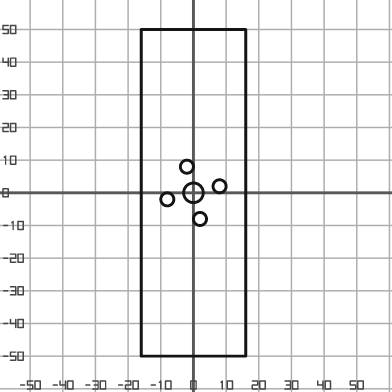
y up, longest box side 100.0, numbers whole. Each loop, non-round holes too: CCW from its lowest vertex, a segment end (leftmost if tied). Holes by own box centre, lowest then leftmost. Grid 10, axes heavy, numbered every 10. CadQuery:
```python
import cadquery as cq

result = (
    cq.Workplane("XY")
    .moveTo(-16.0, -50.0)
    .lineTo(16.0, -50.0)
    .lineTo(16.0, 50.0)
    .lineTo(-16.0, 50.0)
    .close()
    .moveTo(2.0, -8.0)
    .circle(2.0)
    .moveTo(-8.0, -2.0)
    .circle(2.0)
    .moveTo(0.0, 0.0)
    .circle(3.0)
    .moveTo(8.0, 2.0)
    .circle(2.0)
    .moveTo(-2.0, 8.0)
    .circle(2.0)
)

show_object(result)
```